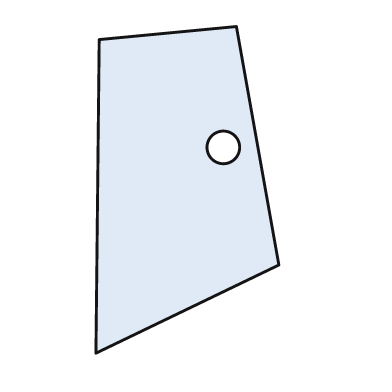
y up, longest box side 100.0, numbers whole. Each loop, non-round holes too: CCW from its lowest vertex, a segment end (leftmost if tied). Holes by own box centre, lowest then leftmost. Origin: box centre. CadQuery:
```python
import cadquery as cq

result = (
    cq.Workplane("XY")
    .moveTo(-28.0, -50.0)
    .lineTo(28.0, -23.0)
    .lineTo(15.0, 50.0)
    .lineTo(-27.0, 46.0)
    .close()
    .moveTo(11.0, 13.0)
    .circle(5.0)
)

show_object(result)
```